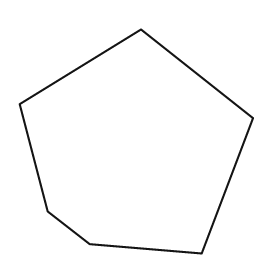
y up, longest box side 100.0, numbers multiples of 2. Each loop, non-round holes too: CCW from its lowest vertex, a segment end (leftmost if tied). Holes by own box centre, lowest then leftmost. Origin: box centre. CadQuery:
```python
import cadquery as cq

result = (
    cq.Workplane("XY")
    .moveTo(28.0, -48.0)
    .lineTo(50.0, 10.0)
    .lineTo(2.0, 48.0)
    .lineTo(-50.0, 16.0)
    .lineTo(-38.0, -30.0)
    .lineTo(-20.0, -44.0)
    .close()
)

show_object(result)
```